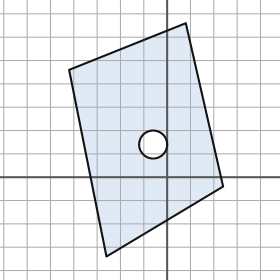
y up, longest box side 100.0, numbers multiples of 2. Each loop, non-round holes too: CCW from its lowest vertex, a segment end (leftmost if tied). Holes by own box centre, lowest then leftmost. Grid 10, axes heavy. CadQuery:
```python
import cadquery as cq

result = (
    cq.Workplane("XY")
    .moveTo(-26.0, -34.0)
    .lineTo(24.0, -4.0)
    .lineTo(8.0, 66.0)
    .lineTo(-42.0, 46.0)
    .close()
    .moveTo(-6.0, 14.0)
    .circle(6.0)
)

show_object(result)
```